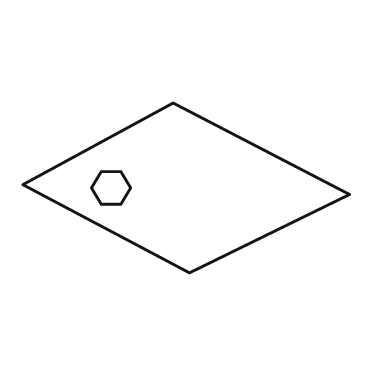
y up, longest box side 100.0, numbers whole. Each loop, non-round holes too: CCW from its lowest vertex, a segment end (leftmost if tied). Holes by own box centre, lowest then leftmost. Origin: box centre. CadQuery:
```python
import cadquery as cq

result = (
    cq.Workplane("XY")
    .moveTo(1.0, -26.0)
    .lineTo(50.0, -2.0)
    .lineTo(-4.0, 26.0)
    .lineTo(-50.0, 1.0)
    .close()
    .moveTo(-26.0, -5.0)
    .lineTo(-20.0, -5.0)
    .lineTo(-17.0, 0.0)
    .lineTo(-20.0, 5.0)
    .lineTo(-26.0, 5.0)
    .lineTo(-29.0, 0.0)
    .close()
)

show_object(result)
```